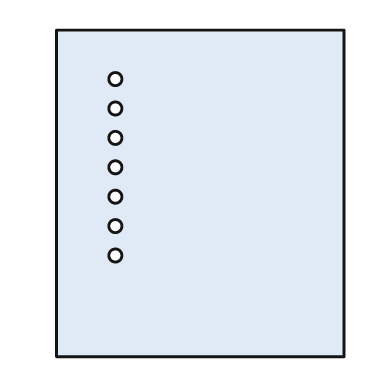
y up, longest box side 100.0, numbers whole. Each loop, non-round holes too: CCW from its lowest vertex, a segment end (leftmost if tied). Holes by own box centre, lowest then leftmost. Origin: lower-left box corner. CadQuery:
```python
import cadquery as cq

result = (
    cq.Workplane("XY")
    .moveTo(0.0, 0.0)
    .lineTo(88.0, 0.0)
    .lineTo(88.0, 100.0)
    .lineTo(0.0, 100.0)
    .close()
    .moveTo(18.0, 31.0)
    .circle(2.0)
    .moveTo(18.0, 40.0)
    .circle(2.0)
    .moveTo(18.0, 49.0)
    .circle(2.0)
    .moveTo(18.0, 58.0)
    .circle(2.0)
    .moveTo(18.0, 67.0)
    .circle(2.0)
    .moveTo(18.0, 76.0)
    .circle(2.0)
    .moveTo(18.0, 85.0)
    .circle(2.0)
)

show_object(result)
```